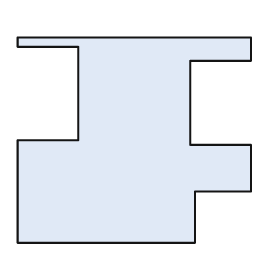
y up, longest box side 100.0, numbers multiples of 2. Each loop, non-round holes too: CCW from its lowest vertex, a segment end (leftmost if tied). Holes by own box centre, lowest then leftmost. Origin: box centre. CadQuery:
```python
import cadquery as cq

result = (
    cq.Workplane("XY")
    .moveTo(-50.0, -44.0)
    .lineTo(26.0, -44.0)
    .lineTo(26.0, -22.0)
    .lineTo(50.0, -22.0)
    .lineTo(50.0, -2.0)
    .lineTo(24.0, -2.0)
    .lineTo(24.0, 34.0)
    .lineTo(50.0, 34.0)
    .lineTo(50.0, 44.0)
    .lineTo(-50.0, 44.0)
    .lineTo(-50.0, 40.0)
    .lineTo(-24.0, 40.0)
    .lineTo(-24.0, 0.0)
    .lineTo(-50.0, 0.0)
    .close()
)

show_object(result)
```